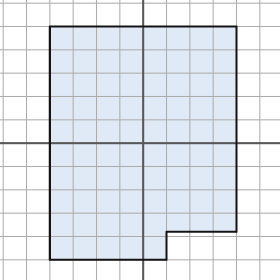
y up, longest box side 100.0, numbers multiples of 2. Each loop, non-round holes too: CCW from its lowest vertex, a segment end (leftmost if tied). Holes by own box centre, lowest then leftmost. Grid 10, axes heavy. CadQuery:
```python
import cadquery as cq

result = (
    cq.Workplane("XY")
    .moveTo(-40.0, -50.0)
    .lineTo(10.0, -50.0)
    .lineTo(10.0, -38.0)
    .lineTo(40.0, -38.0)
    .lineTo(40.0, 50.0)
    .lineTo(-40.0, 50.0)
    .close()
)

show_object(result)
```